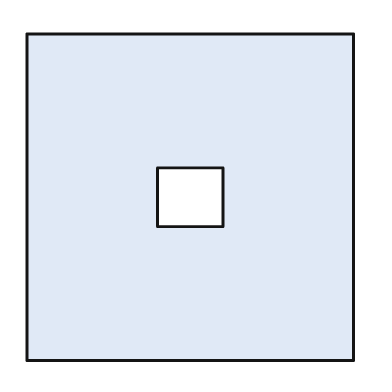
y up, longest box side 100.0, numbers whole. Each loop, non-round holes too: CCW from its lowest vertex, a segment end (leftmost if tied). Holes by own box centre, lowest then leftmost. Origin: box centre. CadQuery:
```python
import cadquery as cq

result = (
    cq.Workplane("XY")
    .moveTo(-50.0, -50.0)
    .lineTo(50.0, -50.0)
    .lineTo(50.0, 50.0)
    .lineTo(-50.0, 50.0)
    .close()
    .moveTo(-10.0, -9.0)
    .lineTo(10.0, -9.0)
    .lineTo(10.0, 9.0)
    .lineTo(-10.0, 9.0)
    .close()
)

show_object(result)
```